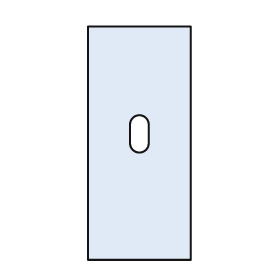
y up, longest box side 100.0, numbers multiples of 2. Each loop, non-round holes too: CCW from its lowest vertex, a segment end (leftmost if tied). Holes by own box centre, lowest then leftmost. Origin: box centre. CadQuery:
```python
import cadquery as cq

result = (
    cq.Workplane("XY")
    .moveTo(-22.0, -50.0)
    .lineTo(22.0, -50.0)
    .lineTo(22.0, 50.0)
    .lineTo(-22.0, 50.0)
    .close()
    .moveTo(-4.0, 0.0)
    .threePointArc((0.0, -4.0), (4.0, 0.0))
    .lineTo(4.0, 8.0)
    .threePointArc((0.0, 12.0), (-4.0, 8.0))
    .close()
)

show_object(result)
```